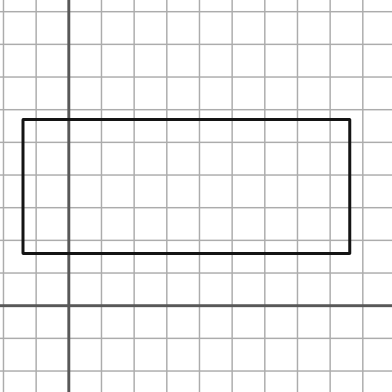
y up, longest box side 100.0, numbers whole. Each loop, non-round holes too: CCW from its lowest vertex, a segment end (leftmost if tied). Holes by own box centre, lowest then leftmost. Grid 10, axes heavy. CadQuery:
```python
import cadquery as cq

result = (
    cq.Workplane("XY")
    .moveTo(-14.0, 16.0)
    .lineTo(86.0, 16.0)
    .lineTo(86.0, 57.0)
    .lineTo(-14.0, 57.0)
    .close()
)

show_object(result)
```